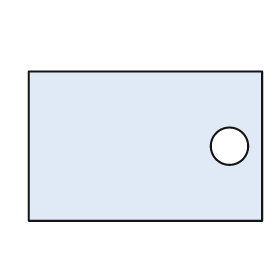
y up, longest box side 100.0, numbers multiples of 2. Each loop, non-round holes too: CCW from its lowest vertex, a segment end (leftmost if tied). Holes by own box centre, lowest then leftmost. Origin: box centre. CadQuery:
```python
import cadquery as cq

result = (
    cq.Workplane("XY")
    .moveTo(-50.0, -32.0)
    .lineTo(50.0, -32.0)
    .lineTo(50.0, 32.0)
    .lineTo(-50.0, 32.0)
    .close()
    .moveTo(36.0, 0.0)
    .circle(8.0)
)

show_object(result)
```